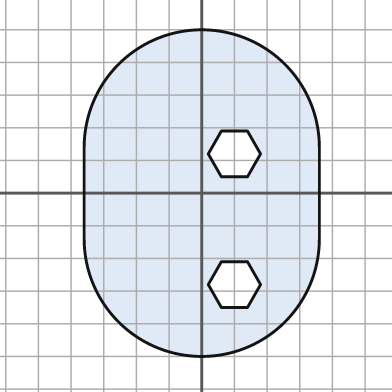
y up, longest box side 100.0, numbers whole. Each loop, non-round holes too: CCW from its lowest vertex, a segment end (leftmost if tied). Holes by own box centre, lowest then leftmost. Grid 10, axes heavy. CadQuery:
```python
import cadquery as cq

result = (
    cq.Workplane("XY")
    .moveTo(-36.0, -14.0)
    .threePointArc((0.0, -50.0), (36.0, -14.0))
    .lineTo(36.0, 14.0)
    .threePointArc((0.0, 50.0), (-36.0, 14.0))
    .close()
    .moveTo(6.0, -35.0)
    .lineTo(14.0, -35.0)
    .lineTo(18.0, -28.0)
    .lineTo(14.0, -21.0)
    .lineTo(6.0, -21.0)
    .lineTo(2.0, -28.0)
    .close()
    .moveTo(6.0, 5.0)
    .lineTo(14.0, 5.0)
    .lineTo(18.0, 12.0)
    .lineTo(14.0, 19.0)
    .lineTo(6.0, 19.0)
    .lineTo(2.0, 12.0)
    .close()
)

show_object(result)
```